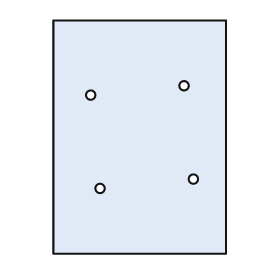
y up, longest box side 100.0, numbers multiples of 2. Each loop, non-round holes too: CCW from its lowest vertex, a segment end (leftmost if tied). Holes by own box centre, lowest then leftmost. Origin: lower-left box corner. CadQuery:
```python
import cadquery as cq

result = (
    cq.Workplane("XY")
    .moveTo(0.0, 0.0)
    .lineTo(74.0, 0.0)
    .lineTo(74.0, 100.0)
    .lineTo(0.0, 100.0)
    .close()
    .moveTo(20.0, 28.0)
    .circle(2.0)
    .moveTo(60.0, 32.0)
    .circle(2.0)
    .moveTo(16.0, 68.0)
    .circle(2.0)
    .moveTo(56.0, 72.0)
    .circle(2.0)
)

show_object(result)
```